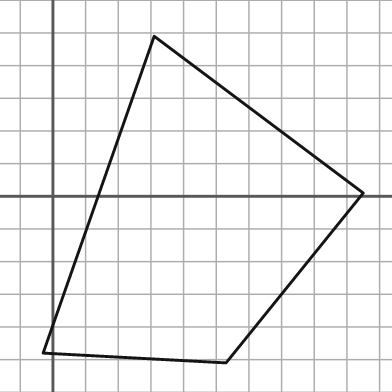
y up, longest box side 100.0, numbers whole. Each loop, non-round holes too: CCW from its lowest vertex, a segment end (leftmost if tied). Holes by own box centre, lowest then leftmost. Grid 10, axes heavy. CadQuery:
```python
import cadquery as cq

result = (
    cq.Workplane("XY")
    .moveTo(53.0, -51.0)
    .lineTo(95.0, 1.0)
    .lineTo(31.0, 49.0)
    .lineTo(-3.0, -48.0)
    .close()
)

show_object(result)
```